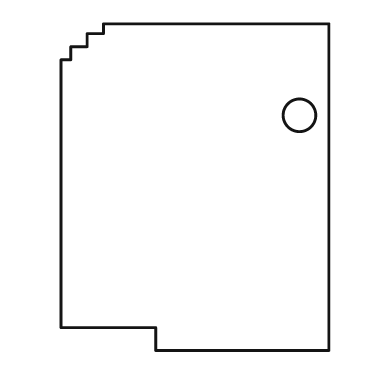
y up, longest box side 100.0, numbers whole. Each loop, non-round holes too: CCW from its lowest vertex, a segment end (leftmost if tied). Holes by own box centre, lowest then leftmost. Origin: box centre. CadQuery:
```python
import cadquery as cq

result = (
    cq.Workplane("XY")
    .moveTo(-12.0, -50.0)
    .lineTo(41.0, -50.0)
    .lineTo(41.0, 50.0)
    .lineTo(-28.0, 50.0)
    .lineTo(-28.0, 47.0)
    .lineTo(-33.0, 47.0)
    .lineTo(-33.0, 43.0)
    .lineTo(-38.0, 43.0)
    .lineTo(-38.0, 39.0)
    .lineTo(-41.0, 39.0)
    .lineTo(-41.0, -43.0)
    .lineTo(-12.0, -43.0)
    .close()
    .moveTo(32.0, 22.0)
    .circle(5.0)
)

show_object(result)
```